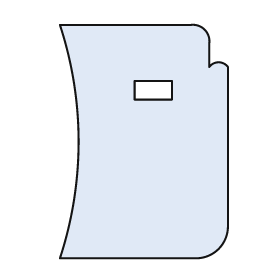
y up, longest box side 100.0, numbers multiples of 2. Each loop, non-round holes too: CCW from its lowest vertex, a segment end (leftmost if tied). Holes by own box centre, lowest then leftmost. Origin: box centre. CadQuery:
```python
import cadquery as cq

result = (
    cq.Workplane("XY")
    .moveTo(-36.0, -50.0)
    .lineTo(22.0, -50.0)
    .threePointArc((32.0, -46.0), (36.0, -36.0))
    .lineTo(36.0, 32.0)
    .threePointArc((32.0, 34.0), (28.0, 32.0))
    .lineTo(28.0, 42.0)
    .threePointArc((26.0, 48.0), (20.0, 50.0))
    .lineTo(-36.0, 50.0)
    .threePointArc((-28.0, 0.0), (-36.0, -50.0))
    .close()
    .moveTo(-4.0, 18.0)
    .lineTo(12.0, 18.0)
    .lineTo(12.0, 26.0)
    .lineTo(-4.0, 26.0)
    .close()
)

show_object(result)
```